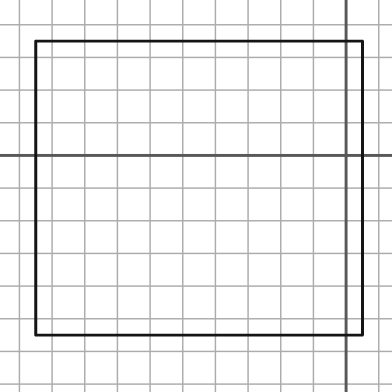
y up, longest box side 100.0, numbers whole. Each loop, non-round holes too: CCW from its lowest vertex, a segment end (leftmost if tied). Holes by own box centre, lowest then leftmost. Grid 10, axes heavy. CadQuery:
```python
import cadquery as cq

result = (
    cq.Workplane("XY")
    .moveTo(-95.0, -55.0)
    .lineTo(5.0, -55.0)
    .lineTo(5.0, 35.0)
    .lineTo(-95.0, 35.0)
    .close()
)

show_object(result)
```